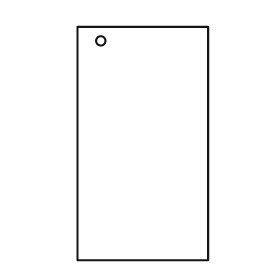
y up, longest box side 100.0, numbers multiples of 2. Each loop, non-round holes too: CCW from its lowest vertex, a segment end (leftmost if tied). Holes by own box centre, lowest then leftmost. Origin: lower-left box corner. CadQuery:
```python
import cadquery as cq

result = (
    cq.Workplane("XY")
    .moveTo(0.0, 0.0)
    .lineTo(56.0, 0.0)
    .lineTo(56.0, 100.0)
    .lineTo(0.0, 100.0)
    .close()
    .moveTo(10.0, 94.0)
    .circle(2.0)
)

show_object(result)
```